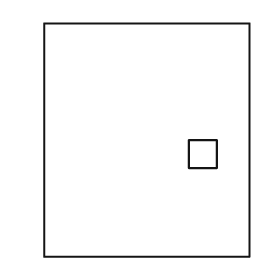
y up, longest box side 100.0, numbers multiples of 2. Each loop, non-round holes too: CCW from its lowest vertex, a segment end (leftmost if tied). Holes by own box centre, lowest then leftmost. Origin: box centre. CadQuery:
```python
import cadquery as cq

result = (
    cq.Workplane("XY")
    .moveTo(-44.0, -50.0)
    .lineTo(44.0, -50.0)
    .lineTo(44.0, 50.0)
    .lineTo(-44.0, 50.0)
    .close()
    .moveTo(18.0, -12.0)
    .lineTo(30.0, -12.0)
    .lineTo(30.0, 0.0)
    .lineTo(18.0, 0.0)
    .close()
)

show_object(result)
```